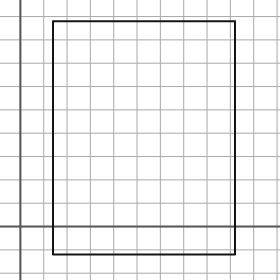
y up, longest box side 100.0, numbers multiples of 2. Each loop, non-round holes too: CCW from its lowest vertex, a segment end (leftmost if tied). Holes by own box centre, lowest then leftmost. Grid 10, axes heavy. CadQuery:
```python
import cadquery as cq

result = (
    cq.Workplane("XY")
    .moveTo(14.0, -12.0)
    .lineTo(92.0, -12.0)
    .lineTo(92.0, 88.0)
    .lineTo(14.0, 88.0)
    .close()
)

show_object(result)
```